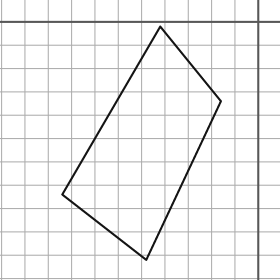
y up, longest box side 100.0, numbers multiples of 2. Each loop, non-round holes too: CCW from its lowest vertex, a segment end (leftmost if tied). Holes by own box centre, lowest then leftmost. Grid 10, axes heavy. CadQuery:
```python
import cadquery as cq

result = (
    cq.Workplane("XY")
    .moveTo(-48.0, -102.0)
    .lineTo(-16.0, -34.0)
    .lineTo(-42.0, -2.0)
    .lineTo(-84.0, -74.0)
    .close()
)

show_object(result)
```